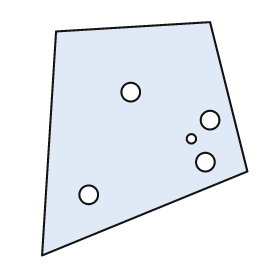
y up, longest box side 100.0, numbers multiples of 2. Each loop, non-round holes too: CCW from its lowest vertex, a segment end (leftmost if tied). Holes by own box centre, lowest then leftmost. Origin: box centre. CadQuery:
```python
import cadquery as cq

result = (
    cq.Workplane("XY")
    .moveTo(-44.0, -50.0)
    .lineTo(44.0, -14.0)
    .lineTo(28.0, 50.0)
    .lineTo(-38.0, 46.0)
    .close()
    .moveTo(-24.0, -24.0)
    .circle(4.0)
    .moveTo(26.0, -10.0)
    .circle(4.0)
    .moveTo(20.0, 0.0)
    .circle(2.0)
    .moveTo(28.0, 8.0)
    .circle(4.0)
    .moveTo(-6.0, 20.0)
    .circle(4.0)
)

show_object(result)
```